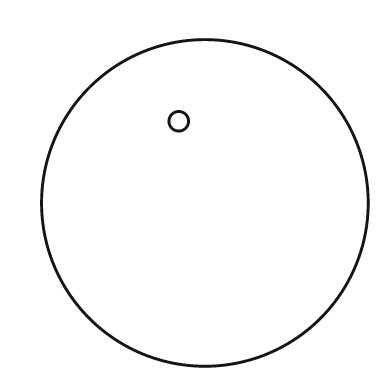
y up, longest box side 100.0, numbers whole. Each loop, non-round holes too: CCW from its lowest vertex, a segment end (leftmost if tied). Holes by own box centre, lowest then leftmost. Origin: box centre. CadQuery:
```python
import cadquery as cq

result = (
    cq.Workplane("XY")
    .moveTo(0.0, 0.0)
    .circle(50.0)
    .moveTo(-8.0, 25.0)
    .circle(3.0)
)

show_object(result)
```